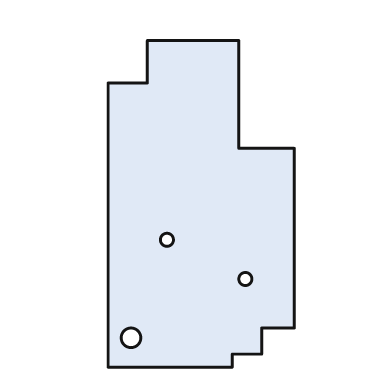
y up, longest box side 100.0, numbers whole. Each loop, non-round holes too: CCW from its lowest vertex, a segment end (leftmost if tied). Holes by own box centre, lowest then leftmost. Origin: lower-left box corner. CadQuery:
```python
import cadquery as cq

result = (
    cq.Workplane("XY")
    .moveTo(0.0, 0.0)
    .lineTo(38.0, 0.0)
    .lineTo(38.0, 4.0)
    .lineTo(47.0, 4.0)
    .lineTo(47.0, 12.0)
    .lineTo(57.0, 12.0)
    .lineTo(57.0, 67.0)
    .lineTo(40.0, 67.0)
    .lineTo(40.0, 100.0)
    .lineTo(12.0, 100.0)
    .lineTo(12.0, 87.0)
    .lineTo(0.0, 87.0)
    .close()
    .moveTo(7.0, 9.0)
    .circle(3.0)
    .moveTo(42.0, 27.0)
    .circle(2.0)
    .moveTo(18.0, 39.0)
    .circle(2.0)
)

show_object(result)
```